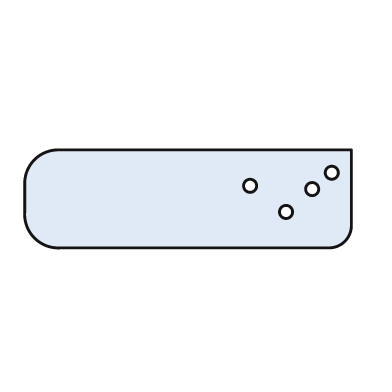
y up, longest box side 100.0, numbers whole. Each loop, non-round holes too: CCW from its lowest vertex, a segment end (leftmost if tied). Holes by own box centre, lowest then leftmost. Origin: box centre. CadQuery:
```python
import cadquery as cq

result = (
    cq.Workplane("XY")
    .moveTo(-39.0, -15.0)
    .lineTo(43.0, -15.0)
    .threePointArc((48.0, -13.0), (50.0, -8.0))
    .lineTo(50.0, 15.0)
    .lineTo(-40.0, 15.0)
    .threePointArc((-47.0, 12.0), (-50.0, 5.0))
    .lineTo(-50.0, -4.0)
    .threePointArc((-47.0, -12.0), (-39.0, -15.0))
    .close()
    .moveTo(30.0, -4.0)
    .circle(2.0)
    .moveTo(38.0, 3.0)
    .circle(2.0)
    .moveTo(19.0, 4.0)
    .circle(2.0)
    .moveTo(44.0, 8.0)
    .circle(2.0)
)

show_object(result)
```